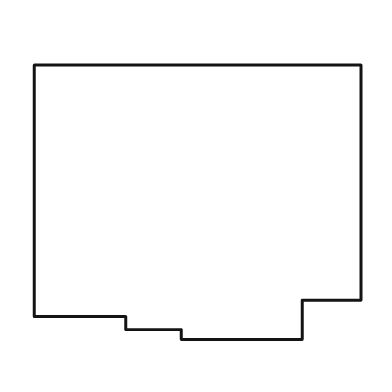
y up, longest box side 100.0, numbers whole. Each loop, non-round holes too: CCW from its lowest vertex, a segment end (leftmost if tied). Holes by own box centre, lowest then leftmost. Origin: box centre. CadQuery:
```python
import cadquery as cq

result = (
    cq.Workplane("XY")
    .moveTo(-5.0, -42.0)
    .lineTo(32.0, -42.0)
    .lineTo(32.0, -30.0)
    .lineTo(50.0, -30.0)
    .lineTo(50.0, 42.0)
    .lineTo(-50.0, 42.0)
    .lineTo(-50.0, -35.0)
    .lineTo(-22.0, -35.0)
    .lineTo(-22.0, -39.0)
    .lineTo(-5.0, -39.0)
    .close()
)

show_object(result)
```